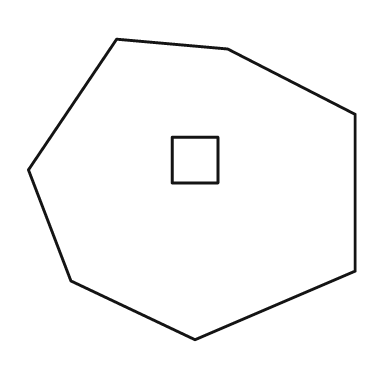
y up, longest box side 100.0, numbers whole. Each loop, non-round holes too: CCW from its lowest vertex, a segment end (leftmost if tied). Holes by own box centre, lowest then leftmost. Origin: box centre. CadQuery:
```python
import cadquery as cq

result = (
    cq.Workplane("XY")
    .moveTo(1.0, -46.0)
    .lineTo(50.0, -25.0)
    .lineTo(50.0, 23.0)
    .lineTo(11.0, 43.0)
    .lineTo(-23.0, 46.0)
    .lineTo(-50.0, 6.0)
    .lineTo(-37.0, -28.0)
    .close()
    .moveTo(-6.0, 2.0)
    .lineTo(8.0, 2.0)
    .lineTo(8.0, 16.0)
    .lineTo(-6.0, 16.0)
    .close()
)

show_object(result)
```